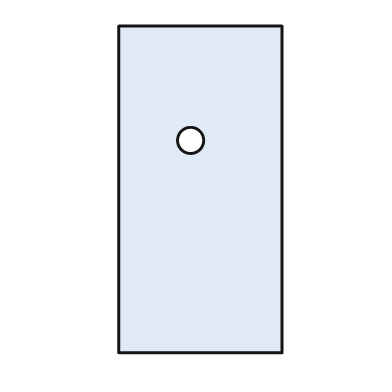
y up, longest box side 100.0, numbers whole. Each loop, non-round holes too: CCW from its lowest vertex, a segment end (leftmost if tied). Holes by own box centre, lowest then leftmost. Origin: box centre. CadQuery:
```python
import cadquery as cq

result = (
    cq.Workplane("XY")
    .moveTo(-25.0, -50.0)
    .lineTo(25.0, -50.0)
    .lineTo(25.0, 50.0)
    .lineTo(-25.0, 50.0)
    .close()
    .moveTo(-3.0, 15.0)
    .circle(4.0)
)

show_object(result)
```